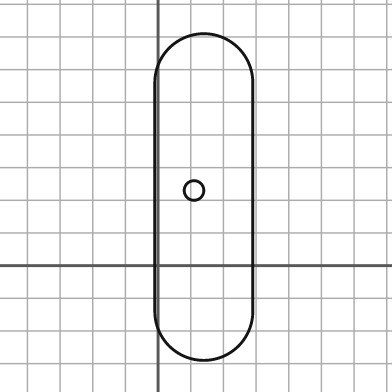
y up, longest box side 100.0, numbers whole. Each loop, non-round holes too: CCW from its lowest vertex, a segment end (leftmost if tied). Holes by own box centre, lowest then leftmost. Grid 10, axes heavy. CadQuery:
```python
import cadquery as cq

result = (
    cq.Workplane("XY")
    .moveTo(-1.0, -14.0)
    .threePointArc((14.0, -29.0), (29.0, -14.0))
    .lineTo(29.0, 56.0)
    .threePointArc((14.0, 71.0), (-1.0, 56.0))
    .close()
    .moveTo(11.0, 23.0)
    .circle(3.0)
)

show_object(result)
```